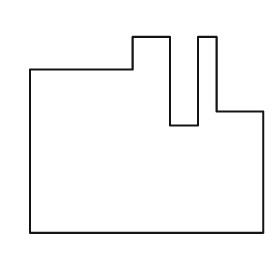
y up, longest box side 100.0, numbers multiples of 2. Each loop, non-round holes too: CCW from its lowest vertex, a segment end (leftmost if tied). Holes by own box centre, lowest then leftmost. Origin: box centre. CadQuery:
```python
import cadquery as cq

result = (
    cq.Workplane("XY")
    .moveTo(-50.0, -42.0)
    .lineTo(50.0, -42.0)
    .lineTo(50.0, 10.0)
    .lineTo(30.0, 10.0)
    .lineTo(30.0, 42.0)
    .lineTo(22.0, 42.0)
    .lineTo(22.0, 4.0)
    .lineTo(10.0, 4.0)
    .lineTo(10.0, 42.0)
    .lineTo(-6.0, 42.0)
    .lineTo(-6.0, 28.0)
    .lineTo(-50.0, 28.0)
    .close()
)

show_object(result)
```